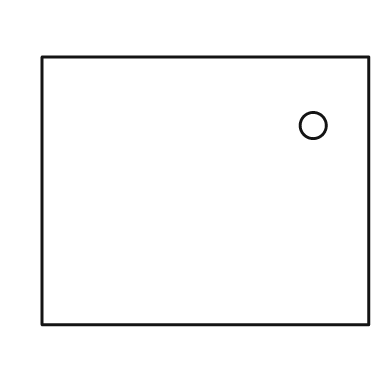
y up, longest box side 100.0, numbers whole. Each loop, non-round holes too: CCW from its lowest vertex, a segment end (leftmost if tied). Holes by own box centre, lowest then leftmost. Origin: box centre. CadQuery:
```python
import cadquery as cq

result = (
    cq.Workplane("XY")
    .moveTo(-50.0, -41.0)
    .lineTo(50.0, -41.0)
    .lineTo(50.0, 41.0)
    .lineTo(-50.0, 41.0)
    .close()
    .moveTo(33.0, 20.0)
    .circle(4.0)
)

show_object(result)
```